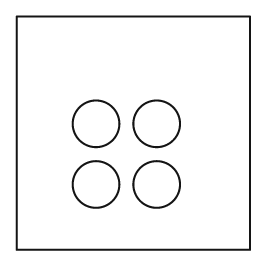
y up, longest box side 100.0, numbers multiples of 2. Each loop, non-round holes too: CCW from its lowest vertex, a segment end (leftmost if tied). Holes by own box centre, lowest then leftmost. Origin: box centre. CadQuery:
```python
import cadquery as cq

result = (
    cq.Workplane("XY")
    .moveTo(-50.0, -50.0)
    .lineTo(50.0, -50.0)
    .lineTo(50.0, 50.0)
    .lineTo(-50.0, 50.0)
    .close()
    .moveTo(-16.0, -22.0)
    .circle(10.0)
    .moveTo(10.0, -22.0)
    .circle(10.0)
    .moveTo(-16.0, 4.0)
    .circle(10.0)
    .moveTo(10.0, 4.0)
    .circle(10.0)
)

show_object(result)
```